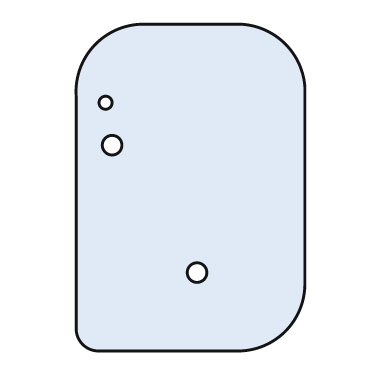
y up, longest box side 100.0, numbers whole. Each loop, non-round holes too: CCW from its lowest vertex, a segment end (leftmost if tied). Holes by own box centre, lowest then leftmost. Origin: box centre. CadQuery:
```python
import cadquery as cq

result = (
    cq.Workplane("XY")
    .moveTo(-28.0, -50.0)
    .lineTo(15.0, -50.0)
    .threePointArc((29.0, -44.0), (35.0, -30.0))
    .lineTo(35.0, 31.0)
    .threePointArc((29.0, 44.0), (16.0, 50.0))
    .lineTo(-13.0, 50.0)
    .threePointArc((-29.0, 44.0), (-35.0, 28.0))
    .lineTo(-35.0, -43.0)
    .threePointArc((-33.0, -48.0), (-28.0, -50.0))
    .close()
    .moveTo(2.0, -26.0)
    .circle(3.0)
    .moveTo(-24.0, 13.0)
    .circle(3.0)
    .moveTo(-26.0, 26.0)
    .circle(2.0)
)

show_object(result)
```